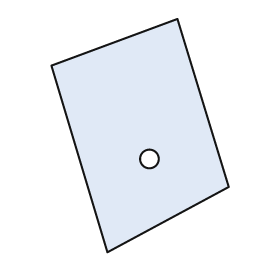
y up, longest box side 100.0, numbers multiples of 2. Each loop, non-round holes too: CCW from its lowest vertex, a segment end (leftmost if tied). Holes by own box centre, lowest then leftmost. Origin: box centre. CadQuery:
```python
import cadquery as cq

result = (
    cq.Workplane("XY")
    .moveTo(-14.0, -50.0)
    .lineTo(38.0, -22.0)
    .lineTo(16.0, 50.0)
    .lineTo(-38.0, 30.0)
    .close()
    .moveTo(4.0, -10.0)
    .circle(4.0)
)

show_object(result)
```